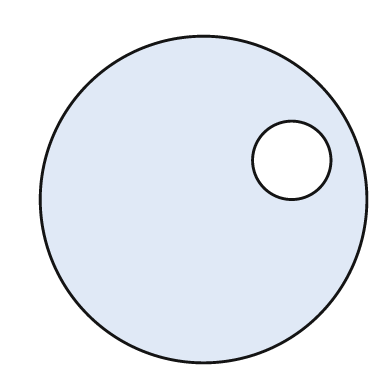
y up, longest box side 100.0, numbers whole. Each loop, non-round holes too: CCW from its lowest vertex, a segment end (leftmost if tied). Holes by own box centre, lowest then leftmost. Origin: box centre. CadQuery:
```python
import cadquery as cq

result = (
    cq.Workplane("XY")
    .moveTo(0.0, 0.0)
    .circle(50.0)
    .moveTo(27.0, 12.0)
    .circle(12.0)
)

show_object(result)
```